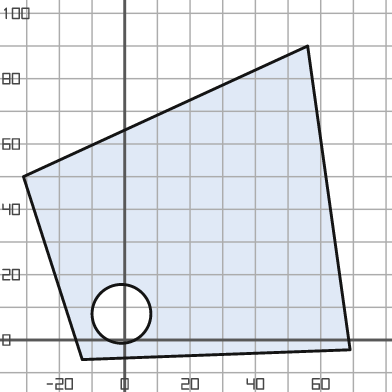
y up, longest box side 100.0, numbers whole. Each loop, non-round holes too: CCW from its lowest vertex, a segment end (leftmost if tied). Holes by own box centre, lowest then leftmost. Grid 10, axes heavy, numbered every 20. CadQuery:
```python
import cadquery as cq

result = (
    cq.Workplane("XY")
    .moveTo(-13.0, -6.0)
    .lineTo(69.0, -3.0)
    .lineTo(56.0, 90.0)
    .lineTo(-31.0, 50.0)
    .close()
    .moveTo(-1.0, 8.0)
    .circle(9.0)
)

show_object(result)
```